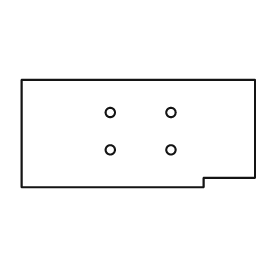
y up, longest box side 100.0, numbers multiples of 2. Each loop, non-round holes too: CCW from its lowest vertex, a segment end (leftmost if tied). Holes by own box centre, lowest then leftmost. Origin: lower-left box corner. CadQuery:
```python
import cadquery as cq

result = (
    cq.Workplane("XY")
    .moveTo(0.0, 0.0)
    .lineTo(78.0, 0.0)
    .lineTo(78.0, 4.0)
    .lineTo(100.0, 4.0)
    .lineTo(100.0, 46.0)
    .lineTo(0.0, 46.0)
    .close()
    .moveTo(38.0, 16.0)
    .circle(2.0)
    .moveTo(64.0, 16.0)
    .circle(2.0)
    .moveTo(38.0, 32.0)
    .circle(2.0)
    .moveTo(64.0, 32.0)
    .circle(2.0)
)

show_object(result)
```